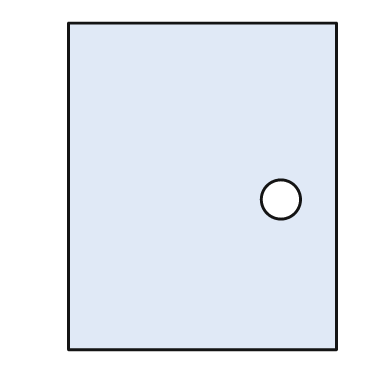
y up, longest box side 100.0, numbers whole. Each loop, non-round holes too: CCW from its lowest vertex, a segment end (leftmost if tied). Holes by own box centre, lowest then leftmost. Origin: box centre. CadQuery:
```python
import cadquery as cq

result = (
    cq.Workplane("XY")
    .moveTo(-41.0, -50.0)
    .lineTo(41.0, -50.0)
    .lineTo(41.0, 50.0)
    .lineTo(-41.0, 50.0)
    .close()
    .moveTo(24.0, -4.0)
    .circle(6.0)
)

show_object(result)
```